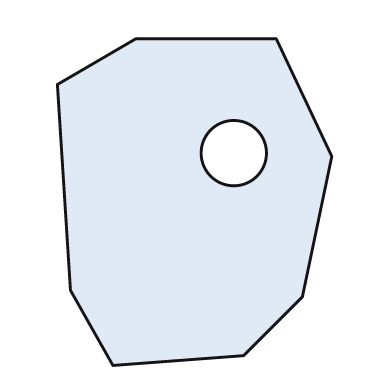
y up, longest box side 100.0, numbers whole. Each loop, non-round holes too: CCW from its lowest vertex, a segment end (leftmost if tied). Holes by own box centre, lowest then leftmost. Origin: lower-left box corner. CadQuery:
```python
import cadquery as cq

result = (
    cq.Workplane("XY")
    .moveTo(17.0, 0.0)
    .lineTo(57.0, 3.0)
    .lineTo(75.0, 21.0)
    .lineTo(84.0, 64.0)
    .lineTo(67.0, 100.0)
    .lineTo(24.0, 100.0)
    .lineTo(0.0, 86.0)
    .lineTo(4.0, 23.0)
    .close()
    .moveTo(54.0, 65.0)
    .circle(10.0)
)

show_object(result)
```